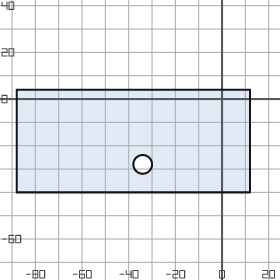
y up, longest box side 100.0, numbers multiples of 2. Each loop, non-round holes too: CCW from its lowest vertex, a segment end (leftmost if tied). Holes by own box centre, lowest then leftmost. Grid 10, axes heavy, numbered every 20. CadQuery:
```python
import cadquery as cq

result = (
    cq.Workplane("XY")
    .moveTo(-88.0, -40.0)
    .lineTo(12.0, -40.0)
    .lineTo(12.0, 4.0)
    .lineTo(-88.0, 4.0)
    .close()
    .moveTo(-34.0, -28.0)
    .circle(4.0)
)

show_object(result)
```